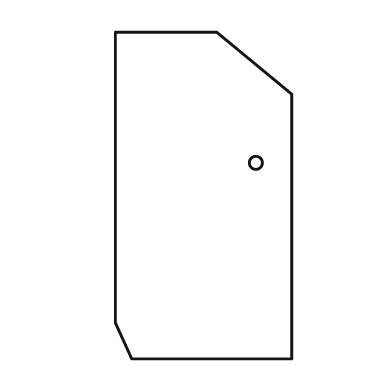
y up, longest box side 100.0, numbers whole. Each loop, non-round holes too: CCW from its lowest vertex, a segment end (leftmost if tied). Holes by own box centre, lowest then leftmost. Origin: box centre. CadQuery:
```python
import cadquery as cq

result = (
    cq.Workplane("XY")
    .moveTo(-22.0, -50.0)
    .lineTo(27.0, -50.0)
    .lineTo(27.0, 31.0)
    .lineTo(4.0, 50.0)
    .lineTo(-27.0, 50.0)
    .lineTo(-27.0, -39.0)
    .close()
    .moveTo(16.0, 10.0)
    .circle(2.0)
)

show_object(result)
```